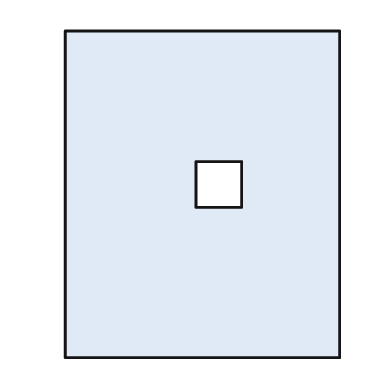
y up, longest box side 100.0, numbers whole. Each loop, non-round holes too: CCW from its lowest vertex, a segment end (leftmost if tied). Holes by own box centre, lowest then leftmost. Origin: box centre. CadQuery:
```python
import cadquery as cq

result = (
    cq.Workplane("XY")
    .moveTo(-42.0, -50.0)
    .lineTo(42.0, -50.0)
    .lineTo(42.0, 50.0)
    .lineTo(-42.0, 50.0)
    .close()
    .moveTo(-2.0, -4.0)
    .lineTo(12.0, -4.0)
    .lineTo(12.0, 10.0)
    .lineTo(-2.0, 10.0)
    .close()
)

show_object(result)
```